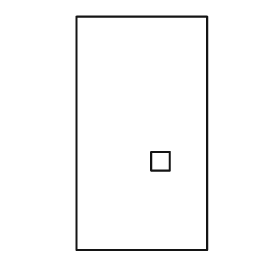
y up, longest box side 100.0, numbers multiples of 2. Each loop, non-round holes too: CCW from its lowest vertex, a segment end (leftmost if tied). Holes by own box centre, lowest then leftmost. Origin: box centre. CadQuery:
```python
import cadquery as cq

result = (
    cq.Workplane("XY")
    .moveTo(-28.0, -50.0)
    .lineTo(28.0, -50.0)
    .lineTo(28.0, 50.0)
    .lineTo(-28.0, 50.0)
    .close()
    .moveTo(4.0, -16.0)
    .lineTo(12.0, -16.0)
    .lineTo(12.0, -8.0)
    .lineTo(4.0, -8.0)
    .close()
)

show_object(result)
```